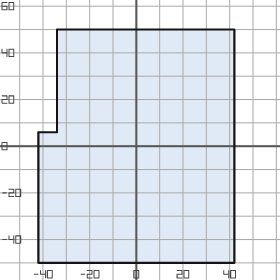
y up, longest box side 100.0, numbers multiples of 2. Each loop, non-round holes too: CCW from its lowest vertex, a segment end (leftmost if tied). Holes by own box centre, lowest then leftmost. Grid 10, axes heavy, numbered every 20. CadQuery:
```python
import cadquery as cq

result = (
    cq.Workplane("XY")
    .moveTo(-42.0, -50.0)
    .lineTo(42.0, -50.0)
    .lineTo(42.0, 50.0)
    .lineTo(-34.0, 50.0)
    .lineTo(-34.0, 6.0)
    .lineTo(-42.0, 6.0)
    .close()
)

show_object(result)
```